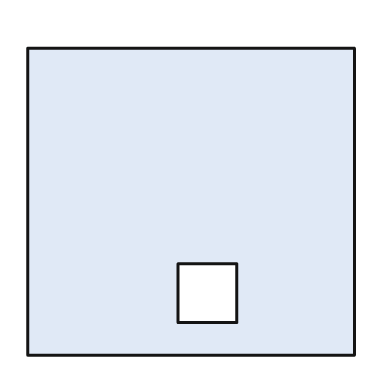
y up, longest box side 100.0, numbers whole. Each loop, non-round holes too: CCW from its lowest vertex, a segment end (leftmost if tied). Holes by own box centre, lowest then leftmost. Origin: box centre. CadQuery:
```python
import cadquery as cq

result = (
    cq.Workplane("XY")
    .moveTo(-50.0, -47.0)
    .lineTo(50.0, -47.0)
    .lineTo(50.0, 47.0)
    .lineTo(-50.0, 47.0)
    .close()
    .moveTo(-4.0, -37.0)
    .lineTo(14.0, -37.0)
    .lineTo(14.0, -19.0)
    .lineTo(-4.0, -19.0)
    .close()
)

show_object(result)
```